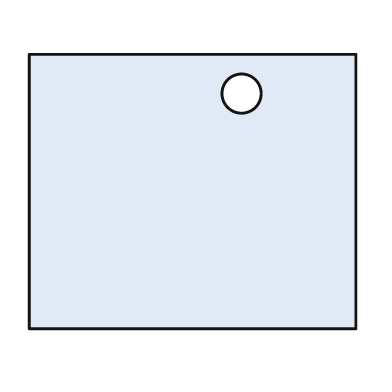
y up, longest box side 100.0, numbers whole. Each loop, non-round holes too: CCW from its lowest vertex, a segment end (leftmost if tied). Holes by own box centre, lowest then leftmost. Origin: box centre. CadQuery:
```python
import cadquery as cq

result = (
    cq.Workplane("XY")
    .moveTo(-50.0, -42.0)
    .lineTo(50.0, -42.0)
    .lineTo(50.0, 42.0)
    .lineTo(-50.0, 42.0)
    .close()
    .moveTo(15.0, 30.0)
    .circle(6.0)
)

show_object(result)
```